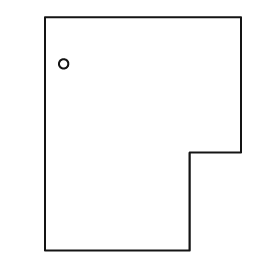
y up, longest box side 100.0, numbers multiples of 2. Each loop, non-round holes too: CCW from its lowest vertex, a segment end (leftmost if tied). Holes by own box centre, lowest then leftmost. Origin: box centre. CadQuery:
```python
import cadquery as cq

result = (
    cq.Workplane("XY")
    .moveTo(-42.0, -50.0)
    .lineTo(20.0, -50.0)
    .lineTo(20.0, -8.0)
    .lineTo(42.0, -8.0)
    .lineTo(42.0, 50.0)
    .lineTo(-42.0, 50.0)
    .close()
    .moveTo(-34.0, 30.0)
    .circle(2.0)
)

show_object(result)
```